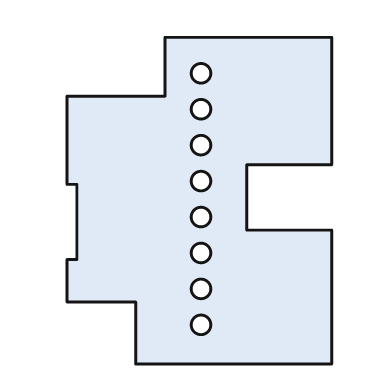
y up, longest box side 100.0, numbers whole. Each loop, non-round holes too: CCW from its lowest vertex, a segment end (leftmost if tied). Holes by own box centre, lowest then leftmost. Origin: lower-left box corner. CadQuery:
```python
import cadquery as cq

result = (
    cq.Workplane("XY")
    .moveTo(21.0, 0.0)
    .lineTo(81.0, 0.0)
    .lineTo(81.0, 41.0)
    .lineTo(55.0, 41.0)
    .lineTo(55.0, 61.0)
    .lineTo(81.0, 61.0)
    .lineTo(81.0, 100.0)
    .lineTo(30.0, 100.0)
    .lineTo(30.0, 82.0)
    .lineTo(0.0, 82.0)
    .lineTo(0.0, 55.0)
    .lineTo(3.0, 55.0)
    .lineTo(3.0, 32.0)
    .lineTo(0.0, 32.0)
    .lineTo(0.0, 19.0)
    .lineTo(21.0, 19.0)
    .close()
    .moveTo(41.0, 12.0)
    .circle(3.0)
    .moveTo(41.0, 23.0)
    .circle(3.0)
    .moveTo(41.0, 34.0)
    .circle(3.0)
    .moveTo(41.0, 45.0)
    .circle(3.0)
    .moveTo(41.0, 56.0)
    .circle(3.0)
    .moveTo(41.0, 67.0)
    .circle(3.0)
    .moveTo(41.0, 78.0)
    .circle(3.0)
    .moveTo(41.0, 89.0)
    .circle(3.0)
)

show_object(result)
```